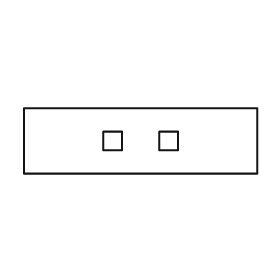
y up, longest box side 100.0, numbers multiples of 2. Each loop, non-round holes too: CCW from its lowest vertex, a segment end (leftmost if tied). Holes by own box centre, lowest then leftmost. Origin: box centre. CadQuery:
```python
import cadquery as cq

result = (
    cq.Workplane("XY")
    .moveTo(-50.0, -14.0)
    .lineTo(50.0, -14.0)
    .lineTo(50.0, 14.0)
    .lineTo(-50.0, 14.0)
    .close()
    .moveTo(-16.0, -4.0)
    .lineTo(-8.0, -4.0)
    .lineTo(-8.0, 4.0)
    .lineTo(-16.0, 4.0)
    .close()
    .moveTo(8.0, -4.0)
    .lineTo(16.0, -4.0)
    .lineTo(16.0, 4.0)
    .lineTo(8.0, 4.0)
    .close()
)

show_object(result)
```